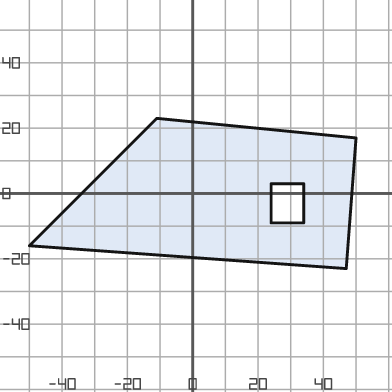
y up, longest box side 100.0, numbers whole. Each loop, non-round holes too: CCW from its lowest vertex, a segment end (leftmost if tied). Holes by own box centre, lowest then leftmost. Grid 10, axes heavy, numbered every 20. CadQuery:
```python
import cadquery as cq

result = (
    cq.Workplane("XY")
    .moveTo(47.0, -23.0)
    .lineTo(50.0, 17.0)
    .lineTo(-11.0, 23.0)
    .lineTo(-50.0, -16.0)
    .close()
    .moveTo(24.0, -9.0)
    .lineTo(34.0, -9.0)
    .lineTo(34.0, 3.0)
    .lineTo(24.0, 3.0)
    .close()
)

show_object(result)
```